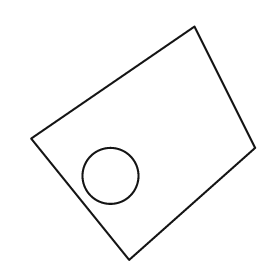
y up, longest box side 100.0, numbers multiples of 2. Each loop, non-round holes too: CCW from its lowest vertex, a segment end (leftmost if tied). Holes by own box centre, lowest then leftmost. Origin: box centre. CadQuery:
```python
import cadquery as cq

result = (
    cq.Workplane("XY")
    .moveTo(-6.0, -50.0)
    .lineTo(48.0, -2.0)
    .lineTo(22.0, 50.0)
    .lineTo(-48.0, 2.0)
    .close()
    .moveTo(-14.0, -14.0)
    .circle(12.0)
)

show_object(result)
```